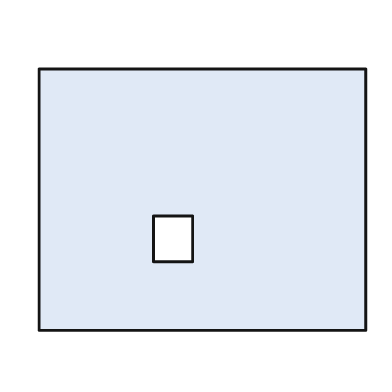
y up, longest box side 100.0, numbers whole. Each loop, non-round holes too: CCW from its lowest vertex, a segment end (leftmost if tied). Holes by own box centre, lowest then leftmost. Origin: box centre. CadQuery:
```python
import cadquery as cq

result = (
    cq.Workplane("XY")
    .moveTo(-50.0, -40.0)
    .lineTo(50.0, -40.0)
    .lineTo(50.0, 40.0)
    .lineTo(-50.0, 40.0)
    .close()
    .moveTo(-15.0, -19.0)
    .lineTo(-3.0, -19.0)
    .lineTo(-3.0, -5.0)
    .lineTo(-15.0, -5.0)
    .close()
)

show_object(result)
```